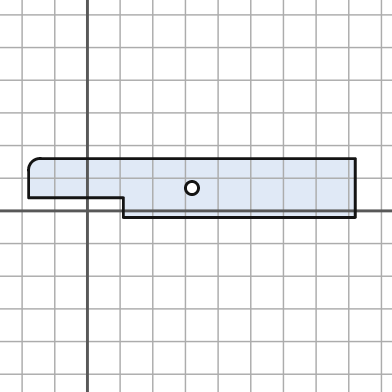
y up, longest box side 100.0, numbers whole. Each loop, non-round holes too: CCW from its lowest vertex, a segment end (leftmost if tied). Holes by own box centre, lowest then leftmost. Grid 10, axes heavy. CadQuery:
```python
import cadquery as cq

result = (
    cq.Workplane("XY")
    .moveTo(11.0, -2.0)
    .lineTo(82.0, -2.0)
    .lineTo(82.0, 16.0)
    .lineTo(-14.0, 16.0)
    .threePointArc((-17.0, 15.0), (-18.0, 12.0))
    .lineTo(-18.0, 4.0)
    .lineTo(11.0, 4.0)
    .close()
    .moveTo(32.0, 7.0)
    .circle(2.0)
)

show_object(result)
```